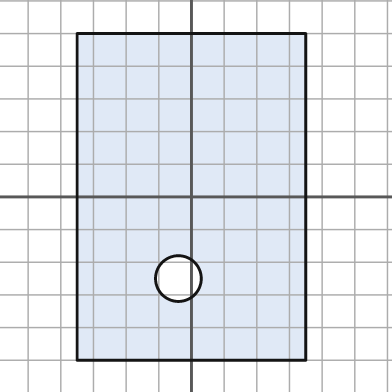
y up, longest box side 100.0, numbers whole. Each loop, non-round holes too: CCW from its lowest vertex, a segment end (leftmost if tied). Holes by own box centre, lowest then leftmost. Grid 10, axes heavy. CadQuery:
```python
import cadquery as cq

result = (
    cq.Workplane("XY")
    .moveTo(-35.0, -50.0)
    .lineTo(35.0, -50.0)
    .lineTo(35.0, 50.0)
    .lineTo(-35.0, 50.0)
    .close()
    .moveTo(-4.0, -25.0)
    .circle(7.0)
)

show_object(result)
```